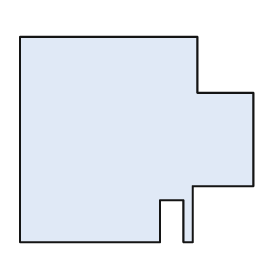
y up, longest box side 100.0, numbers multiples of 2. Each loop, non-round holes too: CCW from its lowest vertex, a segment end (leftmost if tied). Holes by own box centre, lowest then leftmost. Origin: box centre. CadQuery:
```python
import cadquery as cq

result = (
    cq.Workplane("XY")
    .moveTo(-50.0, -44.0)
    .lineTo(10.0, -44.0)
    .lineTo(10.0, -26.0)
    .lineTo(20.0, -26.0)
    .lineTo(20.0, -44.0)
    .lineTo(24.0, -44.0)
    .lineTo(24.0, -20.0)
    .lineTo(50.0, -20.0)
    .lineTo(50.0, 20.0)
    .lineTo(26.0, 20.0)
    .lineTo(26.0, 44.0)
    .lineTo(-50.0, 44.0)
    .close()
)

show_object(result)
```